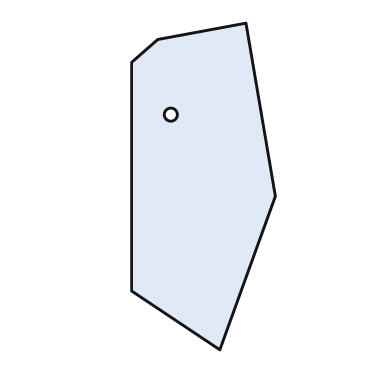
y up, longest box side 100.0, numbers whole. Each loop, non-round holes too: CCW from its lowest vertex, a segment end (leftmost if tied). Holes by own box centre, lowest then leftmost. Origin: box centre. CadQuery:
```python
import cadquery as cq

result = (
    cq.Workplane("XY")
    .moveTo(5.0, -50.0)
    .lineTo(22.0, -3.0)
    .lineTo(13.0, 50.0)
    .lineTo(-14.0, 45.0)
    .lineTo(-22.0, 38.0)
    .lineTo(-22.0, -32.0)
    .close()
    .moveTo(-10.0, 22.0)
    .circle(2.0)
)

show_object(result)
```